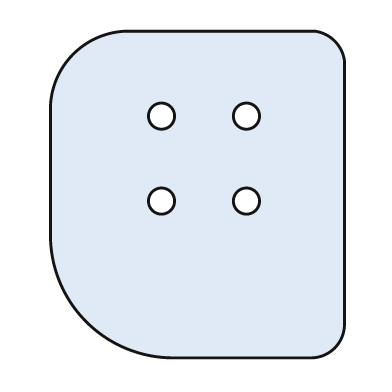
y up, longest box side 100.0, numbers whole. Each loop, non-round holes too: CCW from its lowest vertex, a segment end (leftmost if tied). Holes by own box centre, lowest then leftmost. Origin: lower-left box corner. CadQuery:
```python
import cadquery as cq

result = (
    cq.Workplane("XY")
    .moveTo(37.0, 0.0)
    .lineTo(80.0, 0.0)
    .threePointArc((87.0, 3.0), (90.0, 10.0))
    .lineTo(90.0, 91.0)
    .threePointArc((87.0, 97.0), (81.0, 100.0))
    .lineTo(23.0, 100.0)
    .threePointArc((7.0, 93.0), (0.0, 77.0))
    .lineTo(0.0, 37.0)
    .threePointArc((11.0, 11.0), (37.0, 0.0))
    .close()
    .moveTo(34.0, 48.0)
    .circle(4.0)
    .moveTo(60.0, 48.0)
    .circle(4.0)
    .moveTo(34.0, 74.0)
    .circle(4.0)
    .moveTo(60.0, 74.0)
    .circle(4.0)
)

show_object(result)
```